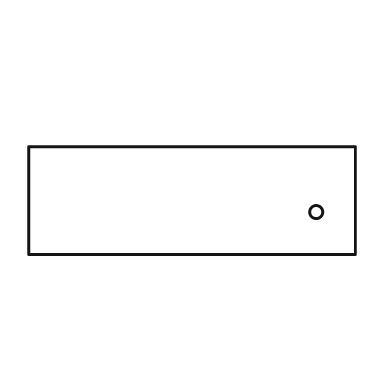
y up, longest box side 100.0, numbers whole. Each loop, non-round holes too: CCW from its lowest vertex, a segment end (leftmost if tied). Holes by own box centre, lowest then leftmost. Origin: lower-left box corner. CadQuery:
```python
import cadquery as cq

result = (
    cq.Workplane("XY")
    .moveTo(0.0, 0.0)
    .lineTo(100.0, 0.0)
    .lineTo(100.0, 33.0)
    .lineTo(0.0, 33.0)
    .close()
    .moveTo(88.0, 13.0)
    .circle(2.0)
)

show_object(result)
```